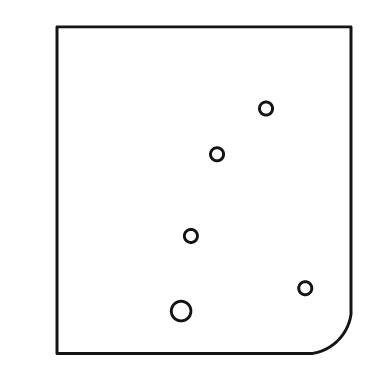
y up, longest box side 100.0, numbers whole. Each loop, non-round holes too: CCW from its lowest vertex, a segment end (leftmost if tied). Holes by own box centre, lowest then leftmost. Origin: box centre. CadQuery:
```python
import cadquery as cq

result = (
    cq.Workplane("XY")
    .moveTo(-45.0, -50.0)
    .lineTo(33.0, -50.0)
    .threePointArc((41.0, -46.0), (45.0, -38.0))
    .lineTo(45.0, 50.0)
    .lineTo(-45.0, 50.0)
    .close()
    .moveTo(-7.0, -37.0)
    .circle(3.0)
    .moveTo(31.0, -30.0)
    .circle(2.0)
    .moveTo(-4.0, -14.0)
    .circle(2.0)
    .moveTo(4.0, 11.0)
    .circle(2.0)
    .moveTo(19.0, 25.0)
    .circle(2.0)
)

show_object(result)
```